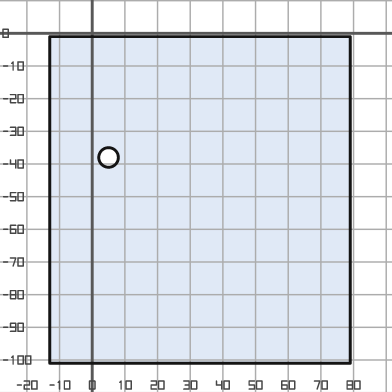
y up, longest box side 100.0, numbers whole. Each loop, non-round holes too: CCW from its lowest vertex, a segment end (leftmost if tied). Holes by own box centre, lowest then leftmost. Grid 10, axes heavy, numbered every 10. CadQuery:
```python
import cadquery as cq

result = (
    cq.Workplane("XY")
    .moveTo(-13.0, -101.0)
    .lineTo(79.0, -101.0)
    .lineTo(79.0, -1.0)
    .lineTo(-13.0, -1.0)
    .close()
    .moveTo(5.0, -38.0)
    .circle(3.0)
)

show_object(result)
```